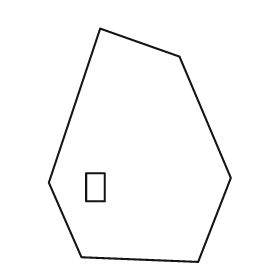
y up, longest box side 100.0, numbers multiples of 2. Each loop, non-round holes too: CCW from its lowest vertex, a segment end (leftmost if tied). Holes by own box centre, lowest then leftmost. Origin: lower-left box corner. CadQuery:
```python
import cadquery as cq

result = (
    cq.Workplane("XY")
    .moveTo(64.0, 0.0)
    .lineTo(78.0, 36.0)
    .lineTo(56.0, 88.0)
    .lineTo(22.0, 100.0)
    .lineTo(0.0, 34.0)
    .lineTo(14.0, 2.0)
    .close()
    .moveTo(16.0, 26.0)
    .lineTo(24.0, 26.0)
    .lineTo(24.0, 38.0)
    .lineTo(16.0, 38.0)
    .close()
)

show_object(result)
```